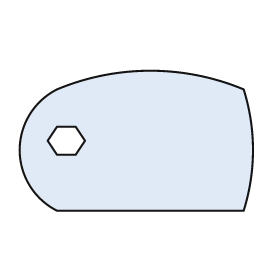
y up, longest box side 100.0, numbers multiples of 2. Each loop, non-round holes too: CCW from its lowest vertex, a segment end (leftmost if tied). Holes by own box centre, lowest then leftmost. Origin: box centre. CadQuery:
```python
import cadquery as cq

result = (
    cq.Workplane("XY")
    .moveTo(-34.0, -30.0)
    .lineTo(46.0, -30.0)
    .threePointArc((50.0, -4.0), (46.0, 22.0))
    .threePointArc((6.0, 30.0), (-34.0, 22.0))
    .threePointArc((-50.0, -4.0), (-34.0, -30.0))
    .close()
    .moveTo(-34.0, -6.0)
    .lineTo(-26.0, -6.0)
    .lineTo(-22.0, 0.0)
    .lineTo(-26.0, 6.0)
    .lineTo(-34.0, 6.0)
    .lineTo(-38.0, 0.0)
    .close()
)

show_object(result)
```